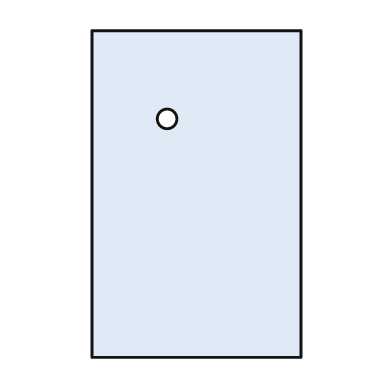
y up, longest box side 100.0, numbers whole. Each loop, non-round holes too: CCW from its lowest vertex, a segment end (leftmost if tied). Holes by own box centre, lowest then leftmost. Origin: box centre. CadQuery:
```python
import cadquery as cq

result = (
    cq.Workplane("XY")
    .moveTo(-32.0, -50.0)
    .lineTo(32.0, -50.0)
    .lineTo(32.0, 50.0)
    .lineTo(-32.0, 50.0)
    .close()
    .moveTo(-9.0, 23.0)
    .circle(3.0)
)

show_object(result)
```